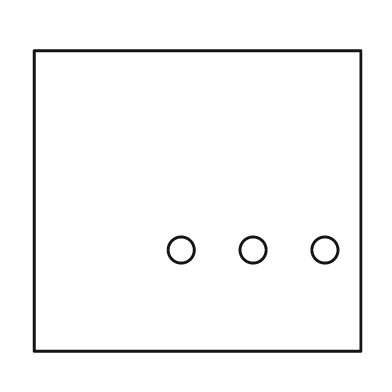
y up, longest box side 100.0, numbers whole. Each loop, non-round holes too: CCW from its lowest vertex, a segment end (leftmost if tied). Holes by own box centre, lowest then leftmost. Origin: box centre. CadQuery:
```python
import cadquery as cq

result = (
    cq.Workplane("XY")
    .moveTo(-50.0, -46.0)
    .lineTo(50.0, -46.0)
    .lineTo(50.0, 46.0)
    .lineTo(-50.0, 46.0)
    .close()
    .moveTo(-5.0, -15.0)
    .circle(4.0)
    .moveTo(17.0, -15.0)
    .circle(4.0)
    .moveTo(39.0, -15.0)
    .circle(4.0)
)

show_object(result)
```